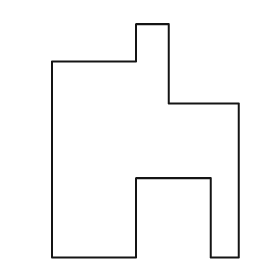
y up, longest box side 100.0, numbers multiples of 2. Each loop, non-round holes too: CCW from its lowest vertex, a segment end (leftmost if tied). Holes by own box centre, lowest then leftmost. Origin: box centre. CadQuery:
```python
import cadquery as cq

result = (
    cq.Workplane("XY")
    .moveTo(-40.0, -50.0)
    .lineTo(-4.0, -50.0)
    .lineTo(-4.0, -16.0)
    .lineTo(28.0, -16.0)
    .lineTo(28.0, -50.0)
    .lineTo(40.0, -50.0)
    .lineTo(40.0, 16.0)
    .lineTo(10.0, 16.0)
    .lineTo(10.0, 50.0)
    .lineTo(-4.0, 50.0)
    .lineTo(-4.0, 34.0)
    .lineTo(-40.0, 34.0)
    .close()
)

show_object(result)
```